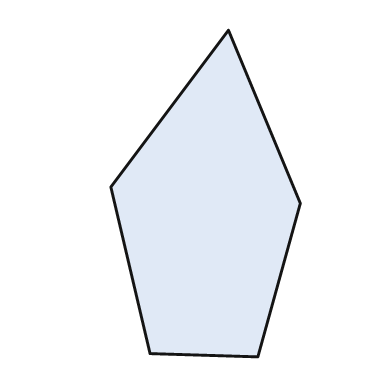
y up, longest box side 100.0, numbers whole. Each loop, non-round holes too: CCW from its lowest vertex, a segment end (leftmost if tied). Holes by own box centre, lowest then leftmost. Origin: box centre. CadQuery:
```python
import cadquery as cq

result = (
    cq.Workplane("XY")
    .moveTo(16.0, -50.0)
    .lineTo(29.0, -3.0)
    .lineTo(7.0, 50.0)
    .lineTo(-29.0, 2.0)
    .lineTo(-17.0, -49.0)
    .close()
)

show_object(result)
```